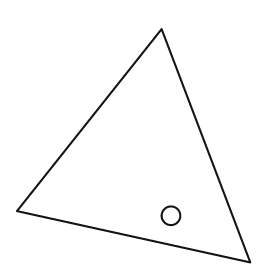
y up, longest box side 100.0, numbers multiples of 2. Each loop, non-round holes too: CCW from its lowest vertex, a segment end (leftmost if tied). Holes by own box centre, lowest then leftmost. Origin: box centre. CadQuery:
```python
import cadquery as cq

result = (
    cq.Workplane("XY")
    .moveTo(50.0, -50.0)
    .lineTo(12.0, 50.0)
    .lineTo(-50.0, -28.0)
    .close()
    .moveTo(16.0, -30.0)
    .circle(4.0)
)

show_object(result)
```